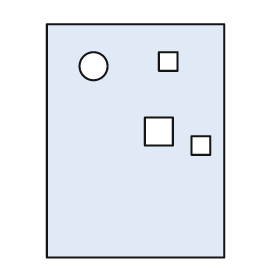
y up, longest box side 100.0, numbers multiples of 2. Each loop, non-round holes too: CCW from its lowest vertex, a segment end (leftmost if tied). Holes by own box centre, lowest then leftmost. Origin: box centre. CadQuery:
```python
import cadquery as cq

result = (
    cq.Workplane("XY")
    .moveTo(-38.0, -50.0)
    .lineTo(38.0, -50.0)
    .lineTo(38.0, 50.0)
    .lineTo(-38.0, 50.0)
    .close()
    .moveTo(24.0, -6.0)
    .lineTo(32.0, -6.0)
    .lineTo(32.0, 2.0)
    .lineTo(24.0, 2.0)
    .close()
    .moveTo(4.0, -2.0)
    .lineTo(16.0, -2.0)
    .lineTo(16.0, 10.0)
    .lineTo(4.0, 10.0)
    .close()
    .moveTo(-18.0, 32.0)
    .circle(6.0)
    .moveTo(10.0, 30.0)
    .lineTo(18.0, 30.0)
    .lineTo(18.0, 38.0)
    .lineTo(10.0, 38.0)
    .close()
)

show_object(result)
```